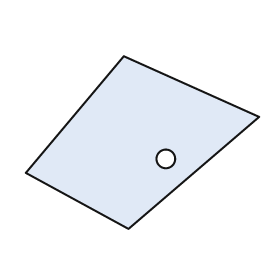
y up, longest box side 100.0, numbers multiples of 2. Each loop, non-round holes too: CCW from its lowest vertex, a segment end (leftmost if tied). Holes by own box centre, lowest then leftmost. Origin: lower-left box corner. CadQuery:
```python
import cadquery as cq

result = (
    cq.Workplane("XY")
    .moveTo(44.0, 0.0)
    .lineTo(100.0, 48.0)
    .lineTo(42.0, 74.0)
    .lineTo(0.0, 24.0)
    .close()
    .moveTo(60.0, 30.0)
    .circle(4.0)
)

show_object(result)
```